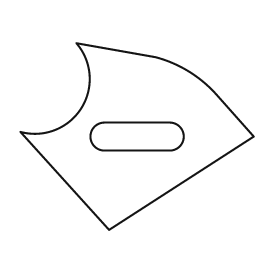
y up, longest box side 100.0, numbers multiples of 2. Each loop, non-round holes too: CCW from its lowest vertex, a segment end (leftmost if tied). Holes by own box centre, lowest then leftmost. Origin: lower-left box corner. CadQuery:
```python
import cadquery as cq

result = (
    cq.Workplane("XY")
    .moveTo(38.0, 0.0)
    .lineTo(100.0, 40.0)
    .lineTo(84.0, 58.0)
    .threePointArc((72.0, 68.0), (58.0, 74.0))
    .lineTo(24.0, 80.0)
    .threePointArc((26.0, 52.0), (0.0, 42.0))
    .close()
    .moveTo(36.0, 34.0)
    .lineTo(64.0, 34.0)
    .threePointArc((70.0, 40.0), (64.0, 46.0))
    .lineTo(36.0, 46.0)
    .threePointArc((30.0, 40.0), (36.0, 34.0))
    .close()
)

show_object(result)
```